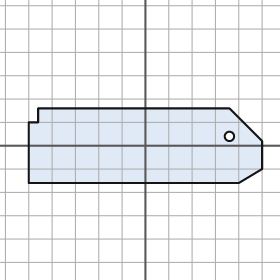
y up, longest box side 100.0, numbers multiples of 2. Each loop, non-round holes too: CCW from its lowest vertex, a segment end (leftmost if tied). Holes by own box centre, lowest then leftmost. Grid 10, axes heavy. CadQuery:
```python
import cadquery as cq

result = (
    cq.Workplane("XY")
    .moveTo(-50.0, -16.0)
    .lineTo(40.0, -16.0)
    .lineTo(50.0, -10.0)
    .lineTo(50.0, 2.0)
    .lineTo(36.0, 16.0)
    .lineTo(-46.0, 16.0)
    .lineTo(-46.0, 10.0)
    .lineTo(-50.0, 10.0)
    .close()
    .moveTo(36.0, 4.0)
    .circle(2.0)
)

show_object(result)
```